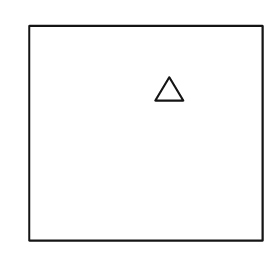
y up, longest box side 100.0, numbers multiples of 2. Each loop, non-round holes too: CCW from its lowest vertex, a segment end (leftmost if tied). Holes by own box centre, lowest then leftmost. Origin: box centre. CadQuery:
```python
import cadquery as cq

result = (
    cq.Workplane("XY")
    .moveTo(-50.0, -46.0)
    .lineTo(50.0, -46.0)
    .lineTo(50.0, 46.0)
    .lineTo(-50.0, 46.0)
    .close()
    .moveTo(4.0, 14.0)
    .lineTo(16.0, 14.0)
    .lineTo(10.0, 24.0)
    .close()
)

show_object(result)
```